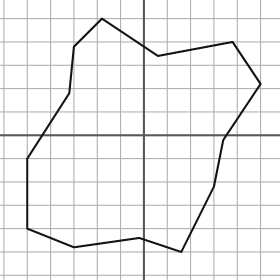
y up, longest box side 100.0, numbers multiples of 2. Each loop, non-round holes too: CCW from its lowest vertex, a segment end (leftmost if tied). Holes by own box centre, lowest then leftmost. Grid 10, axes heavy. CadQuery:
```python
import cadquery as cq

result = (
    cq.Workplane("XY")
    .moveTo(16.0, -50.0)
    .lineTo(30.0, -22.0)
    .lineTo(34.0, -2.0)
    .lineTo(50.0, 22.0)
    .lineTo(38.0, 40.0)
    .lineTo(6.0, 34.0)
    .lineTo(-18.0, 50.0)
    .lineTo(-30.0, 38.0)
    .lineTo(-32.0, 18.0)
    .lineTo(-50.0, -10.0)
    .lineTo(-50.0, -40.0)
    .lineTo(-30.0, -48.0)
    .lineTo(-2.0, -44.0)
    .close()
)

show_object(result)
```